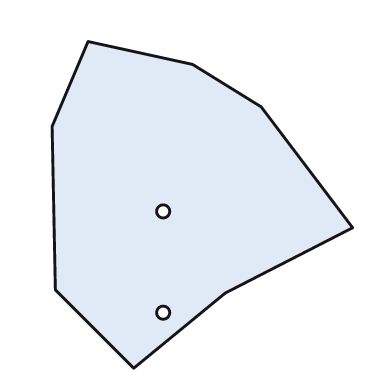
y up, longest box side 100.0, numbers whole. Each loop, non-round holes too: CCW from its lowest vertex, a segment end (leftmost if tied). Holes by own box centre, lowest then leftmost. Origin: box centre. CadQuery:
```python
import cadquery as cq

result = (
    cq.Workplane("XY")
    .moveTo(-21.0, -50.0)
    .lineTo(7.0, -27.0)
    .lineTo(46.0, -7.0)
    .lineTo(18.0, 30.0)
    .lineTo(-3.0, 43.0)
    .lineTo(-35.0, 50.0)
    .lineTo(-46.0, 24.0)
    .lineTo(-45.0, -26.0)
    .close()
    .moveTo(-12.0, -33.0)
    .circle(2.0)
    .moveTo(-12.0, -2.0)
    .circle(2.0)
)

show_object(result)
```